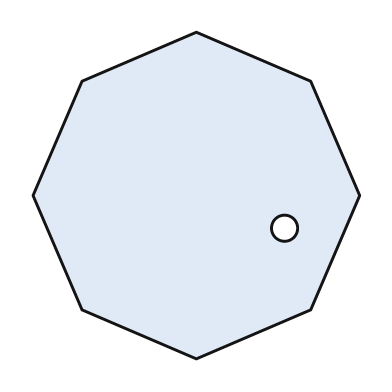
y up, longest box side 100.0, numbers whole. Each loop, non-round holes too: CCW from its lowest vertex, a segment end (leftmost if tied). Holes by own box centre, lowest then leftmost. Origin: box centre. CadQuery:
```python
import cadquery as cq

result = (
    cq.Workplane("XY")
    .moveTo(0.0, -50.0)
    .lineTo(35.0, -35.0)
    .lineTo(50.0, 0.0)
    .lineTo(35.0, 35.0)
    .lineTo(0.0, 50.0)
    .lineTo(-35.0, 35.0)
    .lineTo(-50.0, 0.0)
    .lineTo(-35.0, -35.0)
    .close()
    .moveTo(27.0, -10.0)
    .circle(4.0)
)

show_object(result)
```